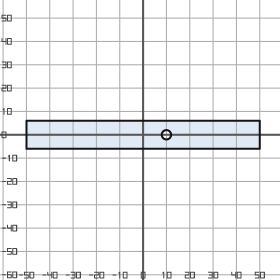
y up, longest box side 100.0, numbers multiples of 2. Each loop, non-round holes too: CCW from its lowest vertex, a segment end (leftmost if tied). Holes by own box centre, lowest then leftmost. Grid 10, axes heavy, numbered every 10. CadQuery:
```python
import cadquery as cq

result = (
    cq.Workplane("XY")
    .moveTo(-50.0, -6.0)
    .lineTo(50.0, -6.0)
    .lineTo(50.0, 6.0)
    .lineTo(-50.0, 6.0)
    .close()
    .moveTo(10.0, 0.0)
    .circle(2.0)
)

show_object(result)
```